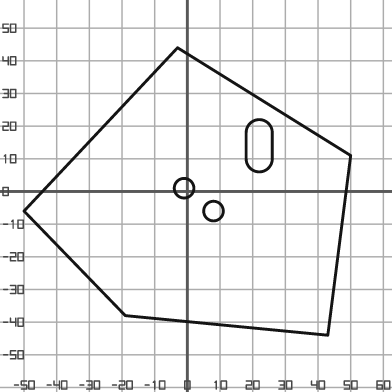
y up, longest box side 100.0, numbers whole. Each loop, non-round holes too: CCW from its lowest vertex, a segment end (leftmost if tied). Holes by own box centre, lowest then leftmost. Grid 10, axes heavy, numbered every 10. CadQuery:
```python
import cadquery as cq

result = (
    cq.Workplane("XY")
    .moveTo(43.0, -44.0)
    .lineTo(50.0, 11.0)
    .lineTo(-3.0, 44.0)
    .lineTo(-50.0, -6.0)
    .lineTo(-19.0, -38.0)
    .close()
    .moveTo(8.0, -6.0)
    .circle(3.0)
    .moveTo(-1.0, 1.0)
    .circle(3.0)
    .moveTo(18.0, 10.0)
    .threePointArc((22.0, 6.0), (26.0, 10.0))
    .lineTo(26.0, 18.0)
    .threePointArc((22.0, 22.0), (18.0, 18.0))
    .close()
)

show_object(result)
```